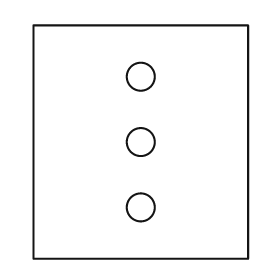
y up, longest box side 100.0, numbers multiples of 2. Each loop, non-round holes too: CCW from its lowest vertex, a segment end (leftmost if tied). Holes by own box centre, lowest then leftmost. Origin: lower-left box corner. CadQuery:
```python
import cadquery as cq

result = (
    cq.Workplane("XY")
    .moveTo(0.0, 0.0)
    .lineTo(92.0, 0.0)
    .lineTo(92.0, 100.0)
    .lineTo(0.0, 100.0)
    .close()
    .moveTo(46.0, 22.0)
    .circle(6.0)
    .moveTo(46.0, 50.0)
    .circle(6.0)
    .moveTo(46.0, 78.0)
    .circle(6.0)
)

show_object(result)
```